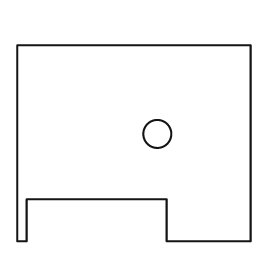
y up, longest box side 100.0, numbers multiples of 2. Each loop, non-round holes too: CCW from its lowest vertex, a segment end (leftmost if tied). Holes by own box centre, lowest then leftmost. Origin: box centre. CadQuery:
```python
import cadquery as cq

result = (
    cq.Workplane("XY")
    .moveTo(-50.0, -42.0)
    .lineTo(-46.0, -42.0)
    .lineTo(-46.0, -24.0)
    .lineTo(14.0, -24.0)
    .lineTo(14.0, -42.0)
    .lineTo(50.0, -42.0)
    .lineTo(50.0, 42.0)
    .lineTo(-50.0, 42.0)
    .close()
    .moveTo(10.0, 4.0)
    .circle(6.0)
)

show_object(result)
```